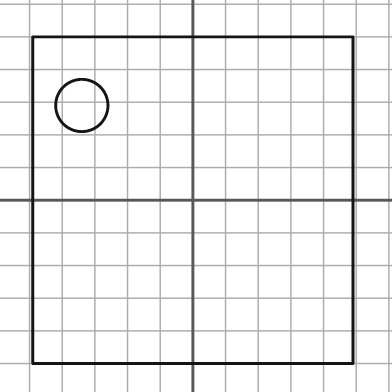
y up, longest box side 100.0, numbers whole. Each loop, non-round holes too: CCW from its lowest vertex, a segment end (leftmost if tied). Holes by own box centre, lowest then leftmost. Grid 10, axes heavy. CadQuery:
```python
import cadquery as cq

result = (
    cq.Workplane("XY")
    .moveTo(-49.0, -50.0)
    .lineTo(49.0, -50.0)
    .lineTo(49.0, 50.0)
    .lineTo(-49.0, 50.0)
    .close()
    .moveTo(-34.0, 29.0)
    .circle(8.0)
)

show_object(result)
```